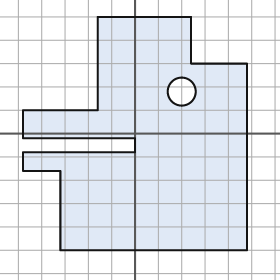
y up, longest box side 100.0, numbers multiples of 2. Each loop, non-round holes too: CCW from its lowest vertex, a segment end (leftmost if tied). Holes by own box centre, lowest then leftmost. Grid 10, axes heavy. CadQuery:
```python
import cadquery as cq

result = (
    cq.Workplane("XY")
    .moveTo(-32.0, -50.0)
    .lineTo(48.0, -50.0)
    .lineTo(48.0, 30.0)
    .lineTo(24.0, 30.0)
    .lineTo(24.0, 50.0)
    .lineTo(-16.0, 50.0)
    .lineTo(-16.0, 10.0)
    .lineTo(-48.0, 10.0)
    .lineTo(-48.0, -2.0)
    .lineTo(0.0, -2.0)
    .lineTo(0.0, -8.0)
    .lineTo(-48.0, -8.0)
    .lineTo(-48.0, -16.0)
    .lineTo(-32.0, -16.0)
    .close()
    .moveTo(20.0, 18.0)
    .circle(6.0)
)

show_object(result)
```